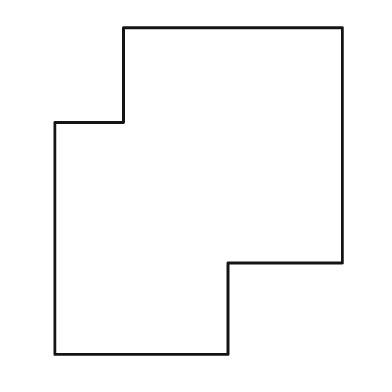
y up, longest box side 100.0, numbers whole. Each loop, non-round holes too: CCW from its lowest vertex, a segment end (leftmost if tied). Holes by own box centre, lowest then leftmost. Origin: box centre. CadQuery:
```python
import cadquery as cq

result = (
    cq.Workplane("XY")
    .moveTo(-44.0, -50.0)
    .lineTo(9.0, -50.0)
    .lineTo(9.0, -22.0)
    .lineTo(44.0, -22.0)
    .lineTo(44.0, 50.0)
    .lineTo(-23.0, 50.0)
    .lineTo(-23.0, 21.0)
    .lineTo(-44.0, 21.0)
    .close()
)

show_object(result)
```